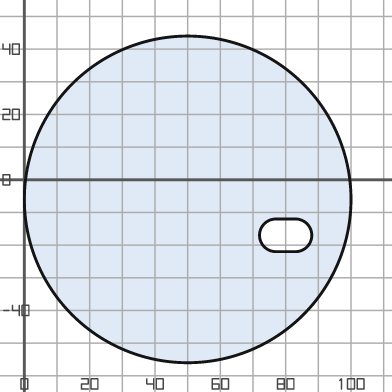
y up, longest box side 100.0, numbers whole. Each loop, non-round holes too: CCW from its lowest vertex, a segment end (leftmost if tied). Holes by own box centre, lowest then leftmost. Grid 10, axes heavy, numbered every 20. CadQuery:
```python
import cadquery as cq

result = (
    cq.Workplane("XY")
    .moveTo(50.0, -6.0)
    .circle(50.0)
    .moveTo(77.0, -22.0)
    .lineTo(83.0, -22.0)
    .threePointArc((88.0, -17.0), (83.0, -12.0))
    .lineTo(77.0, -12.0)
    .threePointArc((72.0, -17.0), (77.0, -22.0))
    .close()
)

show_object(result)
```